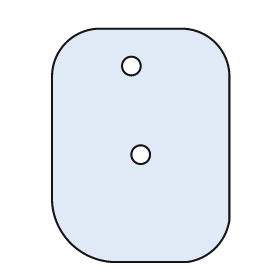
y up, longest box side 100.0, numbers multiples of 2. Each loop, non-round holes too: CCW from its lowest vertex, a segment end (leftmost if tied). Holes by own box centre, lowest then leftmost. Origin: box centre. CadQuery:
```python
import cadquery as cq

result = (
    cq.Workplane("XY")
    .moveTo(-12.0, -50.0)
    .lineTo(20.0, -50.0)
    .threePointArc((32.0, -44.0), (38.0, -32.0))
    .lineTo(38.0, 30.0)
    .threePointArc((32.0, 44.0), (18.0, 50.0))
    .lineTo(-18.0, 50.0)
    .threePointArc((-32.0, 44.0), (-38.0, 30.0))
    .lineTo(-38.0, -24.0)
    .threePointArc((-30.0, -42.0), (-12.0, -50.0))
    .close()
    .moveTo(0.0, -4.0)
    .circle(4.0)
    .moveTo(-4.0, 34.0)
    .circle(4.0)
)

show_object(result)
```